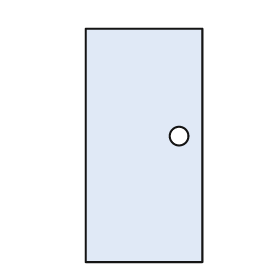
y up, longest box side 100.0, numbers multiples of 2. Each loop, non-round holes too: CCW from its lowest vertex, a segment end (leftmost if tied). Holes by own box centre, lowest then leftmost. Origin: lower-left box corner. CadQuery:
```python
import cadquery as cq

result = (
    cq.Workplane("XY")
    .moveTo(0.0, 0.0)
    .lineTo(50.0, 0.0)
    .lineTo(50.0, 100.0)
    .lineTo(0.0, 100.0)
    .close()
    .moveTo(40.0, 54.0)
    .circle(4.0)
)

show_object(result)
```